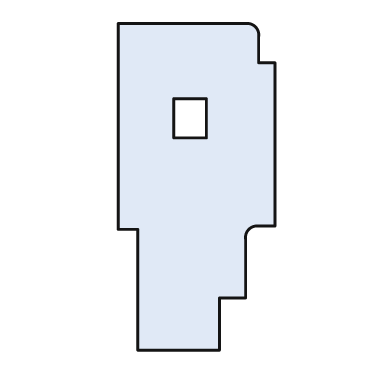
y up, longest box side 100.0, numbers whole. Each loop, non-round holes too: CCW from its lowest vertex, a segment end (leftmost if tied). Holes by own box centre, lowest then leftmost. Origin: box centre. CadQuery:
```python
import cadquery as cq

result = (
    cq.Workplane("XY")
    .moveTo(-18.0, -50.0)
    .lineTo(7.0, -50.0)
    .lineTo(7.0, -34.0)
    .lineTo(15.0, -34.0)
    .lineTo(15.0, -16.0)
    .threePointArc((16.0, -13.0), (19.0, -12.0))
    .lineTo(24.0, -12.0)
    .lineTo(24.0, 38.0)
    .lineTo(19.0, 38.0)
    .lineTo(19.0, 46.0)
    .threePointArc((18.0, 49.0), (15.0, 50.0))
    .lineTo(-24.0, 50.0)
    .lineTo(-24.0, -13.0)
    .lineTo(-18.0, -13.0)
    .close()
    .moveTo(-7.0, 15.0)
    .lineTo(3.0, 15.0)
    .lineTo(3.0, 27.0)
    .lineTo(-7.0, 27.0)
    .close()
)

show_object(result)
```